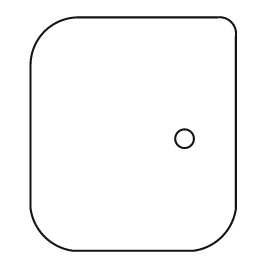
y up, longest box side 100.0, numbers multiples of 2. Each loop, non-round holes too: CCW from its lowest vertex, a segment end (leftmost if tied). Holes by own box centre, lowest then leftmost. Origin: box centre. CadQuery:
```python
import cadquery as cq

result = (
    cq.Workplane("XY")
    .moveTo(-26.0, -50.0)
    .lineTo(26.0, -50.0)
    .threePointArc((38.0, -44.0), (44.0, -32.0))
    .lineTo(44.0, 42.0)
    .threePointArc((42.0, 48.0), (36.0, 50.0))
    .lineTo(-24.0, 50.0)
    .threePointArc((-38.0, 44.0), (-44.0, 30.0))
    .lineTo(-44.0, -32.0)
    .threePointArc((-38.0, -44.0), (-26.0, -50.0))
    .close()
    .moveTo(22.0, -2.0)
    .circle(4.0)
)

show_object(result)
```